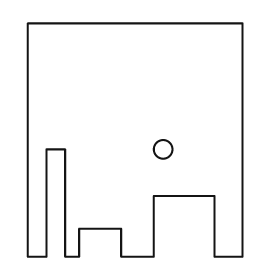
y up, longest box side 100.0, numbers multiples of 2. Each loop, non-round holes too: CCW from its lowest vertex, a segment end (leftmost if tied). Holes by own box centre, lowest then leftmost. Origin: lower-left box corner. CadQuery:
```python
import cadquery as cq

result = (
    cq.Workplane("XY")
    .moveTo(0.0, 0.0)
    .lineTo(8.0, 0.0)
    .lineTo(8.0, 46.0)
    .lineTo(16.0, 46.0)
    .lineTo(16.0, 0.0)
    .lineTo(22.0, 0.0)
    .lineTo(22.0, 12.0)
    .lineTo(40.0, 12.0)
    .lineTo(40.0, 0.0)
    .lineTo(54.0, 0.0)
    .lineTo(54.0, 26.0)
    .lineTo(80.0, 26.0)
    .lineTo(80.0, 0.0)
    .lineTo(92.0, 0.0)
    .lineTo(92.0, 100.0)
    .lineTo(0.0, 100.0)
    .close()
    .moveTo(58.0, 46.0)
    .circle(4.0)
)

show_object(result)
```